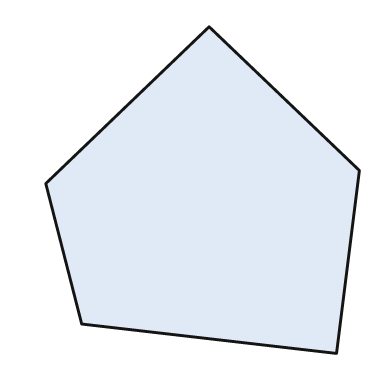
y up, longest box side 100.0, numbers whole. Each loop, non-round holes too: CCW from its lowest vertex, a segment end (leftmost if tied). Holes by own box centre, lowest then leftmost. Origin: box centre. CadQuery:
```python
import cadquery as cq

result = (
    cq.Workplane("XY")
    .moveTo(41.0, -50.0)
    .lineTo(48.0, 6.0)
    .lineTo(2.0, 50.0)
    .lineTo(-48.0, 2.0)
    .lineTo(-37.0, -41.0)
    .close()
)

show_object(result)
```